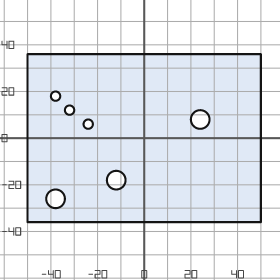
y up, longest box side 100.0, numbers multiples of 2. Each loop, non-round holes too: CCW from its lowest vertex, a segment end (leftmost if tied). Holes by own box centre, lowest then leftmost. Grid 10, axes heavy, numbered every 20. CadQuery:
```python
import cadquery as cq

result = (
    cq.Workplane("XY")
    .moveTo(-50.0, -36.0)
    .lineTo(50.0, -36.0)
    .lineTo(50.0, 36.0)
    .lineTo(-50.0, 36.0)
    .close()
    .moveTo(-38.0, -26.0)
    .circle(4.0)
    .moveTo(-12.0, -18.0)
    .circle(4.0)
    .moveTo(-24.0, 6.0)
    .circle(2.0)
    .moveTo(24.0, 8.0)
    .circle(4.0)
    .moveTo(-32.0, 12.0)
    .circle(2.0)
    .moveTo(-38.0, 18.0)
    .circle(2.0)
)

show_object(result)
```